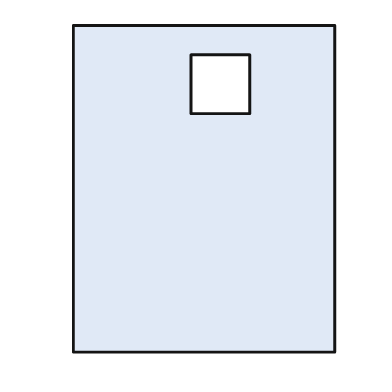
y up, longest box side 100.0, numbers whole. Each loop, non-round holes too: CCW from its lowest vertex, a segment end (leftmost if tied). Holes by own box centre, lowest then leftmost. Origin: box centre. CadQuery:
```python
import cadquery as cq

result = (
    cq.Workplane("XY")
    .moveTo(-40.0, -50.0)
    .lineTo(40.0, -50.0)
    .lineTo(40.0, 50.0)
    .lineTo(-40.0, 50.0)
    .close()
    .moveTo(-4.0, 23.0)
    .lineTo(14.0, 23.0)
    .lineTo(14.0, 41.0)
    .lineTo(-4.0, 41.0)
    .close()
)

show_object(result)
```